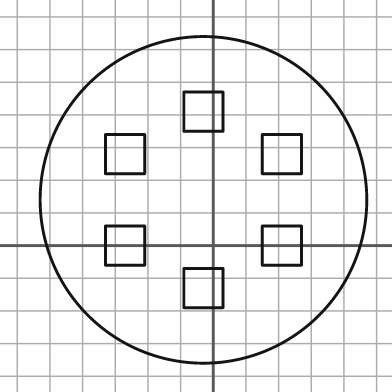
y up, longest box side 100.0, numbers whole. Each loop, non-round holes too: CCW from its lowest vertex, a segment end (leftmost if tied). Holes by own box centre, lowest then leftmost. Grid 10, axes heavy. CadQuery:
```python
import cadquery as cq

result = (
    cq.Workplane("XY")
    .moveTo(-3.0, 14.0)
    .circle(50.0)
    .moveTo(-9.0, -19.0)
    .lineTo(3.0, -19.0)
    .lineTo(3.0, -7.0)
    .lineTo(-9.0, -7.0)
    .close()
    .moveTo(-33.0, -6.0)
    .lineTo(-21.0, -6.0)
    .lineTo(-21.0, 6.0)
    .lineTo(-33.0, 6.0)
    .close()
    .moveTo(15.0, -6.0)
    .lineTo(27.0, -6.0)
    .lineTo(27.0, 6.0)
    .lineTo(15.0, 6.0)
    .close()
    .moveTo(-33.0, 22.0)
    .lineTo(-21.0, 22.0)
    .lineTo(-21.0, 34.0)
    .lineTo(-33.0, 34.0)
    .close()
    .moveTo(15.0, 22.0)
    .lineTo(27.0, 22.0)
    .lineTo(27.0, 34.0)
    .lineTo(15.0, 34.0)
    .close()
    .moveTo(-9.0, 35.0)
    .lineTo(3.0, 35.0)
    .lineTo(3.0, 47.0)
    .lineTo(-9.0, 47.0)
    .close()
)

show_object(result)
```